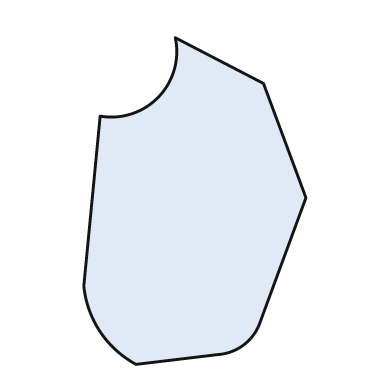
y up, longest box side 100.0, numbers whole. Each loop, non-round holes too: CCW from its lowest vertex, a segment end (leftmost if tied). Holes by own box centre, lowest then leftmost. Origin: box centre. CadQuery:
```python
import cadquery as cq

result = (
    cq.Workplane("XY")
    .moveTo(-18.0, -50.0)
    .lineTo(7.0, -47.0)
    .threePointArc((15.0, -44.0), (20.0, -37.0))
    .lineTo(34.0, 1.0)
    .lineTo(21.0, 36.0)
    .lineTo(-6.0, 50.0)
    .threePointArc((-11.0, 32.0), (-29.0, 26.0))
    .lineTo(-34.0, -26.0)
    .threePointArc((-29.0, -40.0), (-18.0, -50.0))
    .close()
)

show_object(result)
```